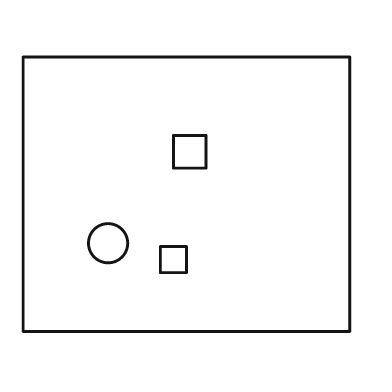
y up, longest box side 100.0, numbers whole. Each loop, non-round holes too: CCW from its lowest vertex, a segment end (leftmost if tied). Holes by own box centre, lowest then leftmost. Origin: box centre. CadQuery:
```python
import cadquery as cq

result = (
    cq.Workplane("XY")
    .moveTo(-50.0, -42.0)
    .lineTo(50.0, -42.0)
    .lineTo(50.0, 42.0)
    .lineTo(-50.0, 42.0)
    .close()
    .moveTo(-8.0, -24.0)
    .lineTo(0.0, -24.0)
    .lineTo(0.0, -16.0)
    .lineTo(-8.0, -16.0)
    .close()
    .moveTo(-24.0, -15.0)
    .circle(6.0)
    .moveTo(-4.0, 8.0)
    .lineTo(6.0, 8.0)
    .lineTo(6.0, 18.0)
    .lineTo(-4.0, 18.0)
    .close()
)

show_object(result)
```